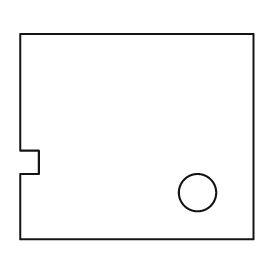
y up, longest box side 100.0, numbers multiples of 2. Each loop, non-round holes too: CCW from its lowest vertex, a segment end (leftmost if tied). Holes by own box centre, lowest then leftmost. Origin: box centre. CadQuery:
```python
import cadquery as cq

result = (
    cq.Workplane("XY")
    .moveTo(-50.0, -44.0)
    .lineTo(50.0, -44.0)
    .lineTo(50.0, 44.0)
    .lineTo(-50.0, 44.0)
    .lineTo(-50.0, -6.0)
    .lineTo(-42.0, -6.0)
    .lineTo(-42.0, -16.0)
    .lineTo(-50.0, -16.0)
    .close()
    .moveTo(26.0, -24.0)
    .circle(8.0)
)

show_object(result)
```